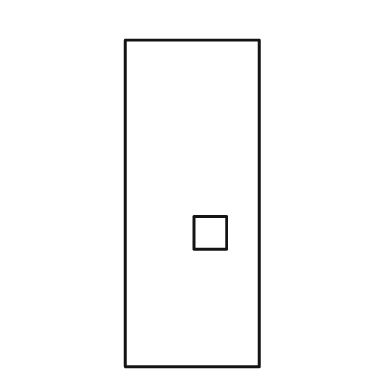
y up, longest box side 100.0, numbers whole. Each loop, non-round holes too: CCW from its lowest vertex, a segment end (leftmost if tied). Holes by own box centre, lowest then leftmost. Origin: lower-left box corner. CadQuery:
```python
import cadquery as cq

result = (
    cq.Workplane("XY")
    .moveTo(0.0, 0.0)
    .lineTo(41.0, 0.0)
    .lineTo(41.0, 100.0)
    .lineTo(0.0, 100.0)
    .close()
    .moveTo(21.0, 36.0)
    .lineTo(31.0, 36.0)
    .lineTo(31.0, 46.0)
    .lineTo(21.0, 46.0)
    .close()
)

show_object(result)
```